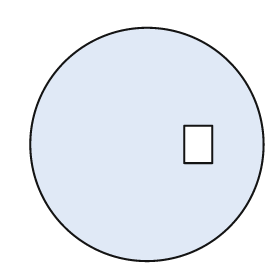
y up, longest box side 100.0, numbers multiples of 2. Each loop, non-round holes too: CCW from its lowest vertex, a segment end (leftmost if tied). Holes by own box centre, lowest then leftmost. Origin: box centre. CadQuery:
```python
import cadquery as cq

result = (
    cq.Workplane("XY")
    .moveTo(0.0, 0.0)
    .circle(50.0)
    .moveTo(16.0, -8.0)
    .lineTo(28.0, -8.0)
    .lineTo(28.0, 8.0)
    .lineTo(16.0, 8.0)
    .close()
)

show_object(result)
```